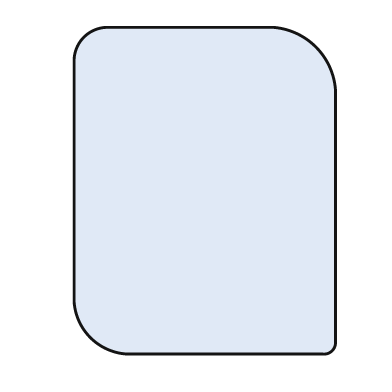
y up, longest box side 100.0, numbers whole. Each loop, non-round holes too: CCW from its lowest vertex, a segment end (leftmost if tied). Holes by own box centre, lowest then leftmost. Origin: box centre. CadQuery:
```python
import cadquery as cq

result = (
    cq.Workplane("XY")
    .moveTo(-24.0, -50.0)
    .lineTo(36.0, -50.0)
    .threePointArc((39.0, -49.0), (40.0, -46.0))
    .lineTo(40.0, 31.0)
    .threePointArc((34.0, 44.0), (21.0, 50.0))
    .lineTo(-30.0, 50.0)
    .threePointArc((-37.0, 47.0), (-40.0, 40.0))
    .lineTo(-40.0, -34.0)
    .threePointArc((-35.0, -45.0), (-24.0, -50.0))
    .close()
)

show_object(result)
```